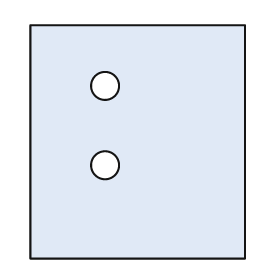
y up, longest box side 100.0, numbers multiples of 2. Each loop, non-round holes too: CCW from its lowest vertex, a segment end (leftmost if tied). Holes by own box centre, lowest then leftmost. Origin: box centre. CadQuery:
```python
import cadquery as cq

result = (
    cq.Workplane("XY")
    .moveTo(-46.0, -50.0)
    .lineTo(46.0, -50.0)
    .lineTo(46.0, 50.0)
    .lineTo(-46.0, 50.0)
    .close()
    .moveTo(-14.0, -10.0)
    .circle(6.0)
    .moveTo(-14.0, 24.0)
    .circle(6.0)
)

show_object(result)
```